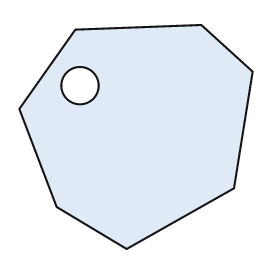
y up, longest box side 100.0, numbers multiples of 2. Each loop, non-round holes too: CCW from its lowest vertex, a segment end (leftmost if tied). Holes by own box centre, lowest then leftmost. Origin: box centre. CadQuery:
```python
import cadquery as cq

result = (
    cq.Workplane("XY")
    .moveTo(-4.0, -48.0)
    .lineTo(42.0, -22.0)
    .lineTo(50.0, 28.0)
    .lineTo(28.0, 48.0)
    .lineTo(-26.0, 46.0)
    .lineTo(-50.0, 12.0)
    .lineTo(-34.0, -30.0)
    .close()
    .moveTo(-24.0, 22.0)
    .circle(8.0)
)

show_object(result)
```